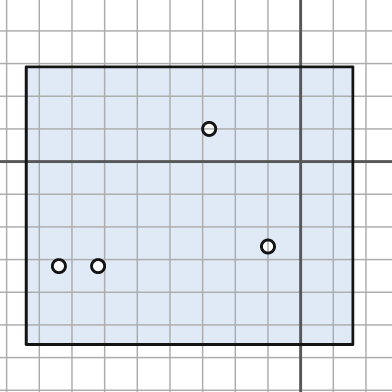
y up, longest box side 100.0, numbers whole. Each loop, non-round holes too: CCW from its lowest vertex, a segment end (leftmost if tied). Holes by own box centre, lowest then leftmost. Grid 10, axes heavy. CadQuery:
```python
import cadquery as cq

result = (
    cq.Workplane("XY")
    .moveTo(-84.0, -56.0)
    .lineTo(16.0, -56.0)
    .lineTo(16.0, 29.0)
    .lineTo(-84.0, 29.0)
    .close()
    .moveTo(-74.0, -32.0)
    .circle(2.0)
    .moveTo(-62.0, -32.0)
    .circle(2.0)
    .moveTo(-10.0, -26.0)
    .circle(2.0)
    .moveTo(-28.0, 10.0)
    .circle(2.0)
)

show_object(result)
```